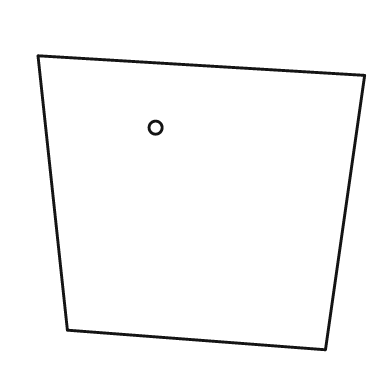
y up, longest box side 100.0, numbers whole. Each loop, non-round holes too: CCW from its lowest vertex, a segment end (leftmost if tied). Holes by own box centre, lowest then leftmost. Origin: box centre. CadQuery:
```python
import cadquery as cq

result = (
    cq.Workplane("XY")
    .moveTo(38.0, -45.0)
    .lineTo(50.0, 39.0)
    .lineTo(-50.0, 45.0)
    .lineTo(-41.0, -39.0)
    .close()
    .moveTo(-14.0, 23.0)
    .circle(2.0)
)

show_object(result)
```